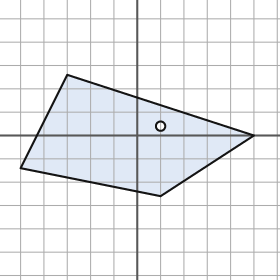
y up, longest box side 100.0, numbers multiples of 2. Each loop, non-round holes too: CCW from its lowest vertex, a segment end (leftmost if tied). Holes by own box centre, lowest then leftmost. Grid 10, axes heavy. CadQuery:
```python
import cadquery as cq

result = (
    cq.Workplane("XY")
    .moveTo(10.0, -26.0)
    .lineTo(50.0, 0.0)
    .lineTo(-30.0, 26.0)
    .lineTo(-50.0, -14.0)
    .close()
    .moveTo(10.0, 4.0)
    .circle(2.0)
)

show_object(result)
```